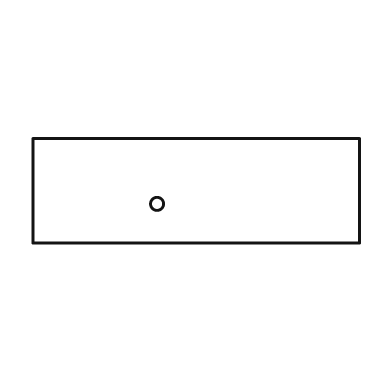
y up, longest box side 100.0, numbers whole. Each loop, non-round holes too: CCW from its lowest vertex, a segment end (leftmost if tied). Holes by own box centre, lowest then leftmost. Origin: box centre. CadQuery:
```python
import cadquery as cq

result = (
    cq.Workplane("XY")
    .moveTo(-50.0, -16.0)
    .lineTo(50.0, -16.0)
    .lineTo(50.0, 16.0)
    .lineTo(-50.0, 16.0)
    .close()
    .moveTo(-12.0, -4.0)
    .circle(2.0)
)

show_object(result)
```